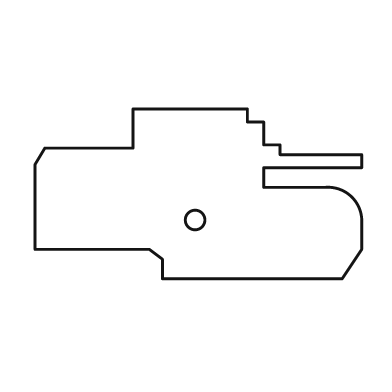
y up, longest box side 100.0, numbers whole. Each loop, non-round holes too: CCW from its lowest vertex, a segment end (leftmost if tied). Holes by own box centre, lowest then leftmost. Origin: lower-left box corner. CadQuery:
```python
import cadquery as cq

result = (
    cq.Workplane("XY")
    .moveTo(39.0, 0.0)
    .lineTo(94.0, 0.0)
    .lineTo(100.0, 9.0)
    .lineTo(100.0, 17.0)
    .threePointArc((97.0, 25.0), (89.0, 28.0))
    .lineTo(70.0, 28.0)
    .lineTo(70.0, 34.0)
    .lineTo(100.0, 34.0)
    .lineTo(100.0, 38.0)
    .lineTo(75.0, 38.0)
    .lineTo(75.0, 41.0)
    .lineTo(70.0, 41.0)
    .lineTo(70.0, 48.0)
    .lineTo(65.0, 48.0)
    .lineTo(65.0, 52.0)
    .lineTo(30.0, 52.0)
    .lineTo(30.0, 40.0)
    .lineTo(3.0, 40.0)
    .lineTo(0.0, 35.0)
    .lineTo(0.0, 9.0)
    .lineTo(35.0, 9.0)
    .lineTo(39.0, 6.0)
    .close()
    .moveTo(49.0, 18.0)
    .circle(3.0)
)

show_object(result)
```